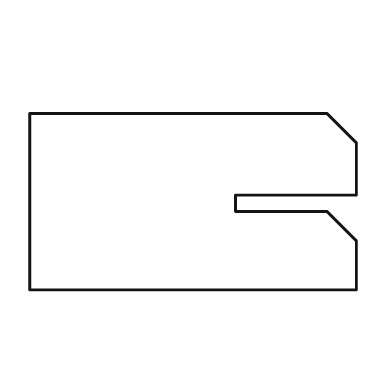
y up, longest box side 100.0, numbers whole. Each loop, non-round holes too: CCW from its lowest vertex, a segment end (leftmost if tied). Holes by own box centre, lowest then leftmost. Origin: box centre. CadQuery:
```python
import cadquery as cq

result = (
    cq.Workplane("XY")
    .moveTo(-50.0, -27.0)
    .lineTo(50.0, -27.0)
    .lineTo(50.0, -12.0)
    .lineTo(41.0, -3.0)
    .lineTo(13.0, -3.0)
    .lineTo(13.0, 2.0)
    .lineTo(50.0, 2.0)
    .lineTo(50.0, 18.0)
    .lineTo(41.0, 27.0)
    .lineTo(-50.0, 27.0)
    .close()
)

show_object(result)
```